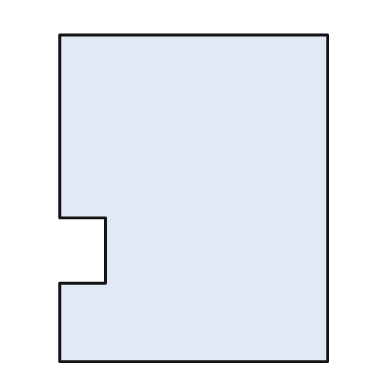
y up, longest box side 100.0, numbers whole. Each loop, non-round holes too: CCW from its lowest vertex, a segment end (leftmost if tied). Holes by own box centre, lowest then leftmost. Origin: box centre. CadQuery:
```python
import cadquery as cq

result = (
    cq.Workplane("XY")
    .moveTo(-41.0, -50.0)
    .lineTo(41.0, -50.0)
    .lineTo(41.0, 50.0)
    .lineTo(-41.0, 50.0)
    .lineTo(-41.0, -6.0)
    .lineTo(-27.0, -6.0)
    .lineTo(-27.0, -26.0)
    .lineTo(-41.0, -26.0)
    .close()
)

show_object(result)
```